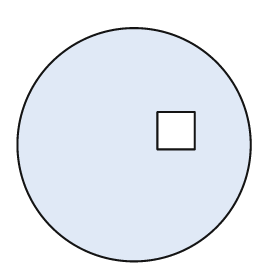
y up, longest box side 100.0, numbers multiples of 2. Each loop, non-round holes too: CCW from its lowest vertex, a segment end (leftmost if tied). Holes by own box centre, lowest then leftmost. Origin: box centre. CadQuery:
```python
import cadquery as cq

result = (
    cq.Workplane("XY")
    .moveTo(0.0, 0.0)
    .circle(50.0)
    .moveTo(10.0, -2.0)
    .lineTo(26.0, -2.0)
    .lineTo(26.0, 14.0)
    .lineTo(10.0, 14.0)
    .close()
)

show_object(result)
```